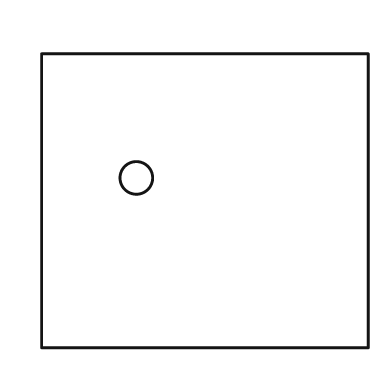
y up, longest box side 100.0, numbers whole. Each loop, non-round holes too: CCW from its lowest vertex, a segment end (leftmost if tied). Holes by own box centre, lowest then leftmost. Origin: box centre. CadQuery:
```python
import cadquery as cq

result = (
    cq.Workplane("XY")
    .moveTo(-50.0, -45.0)
    .lineTo(50.0, -45.0)
    .lineTo(50.0, 45.0)
    .lineTo(-50.0, 45.0)
    .close()
    .moveTo(-21.0, 7.0)
    .circle(5.0)
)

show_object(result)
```